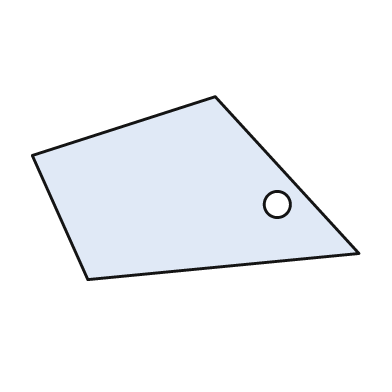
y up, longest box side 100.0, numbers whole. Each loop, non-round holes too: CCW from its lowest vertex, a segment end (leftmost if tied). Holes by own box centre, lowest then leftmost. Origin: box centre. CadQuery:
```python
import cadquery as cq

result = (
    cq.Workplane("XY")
    .moveTo(-33.0, -28.0)
    .lineTo(50.0, -20.0)
    .lineTo(6.0, 28.0)
    .lineTo(-50.0, 10.0)
    .close()
    .moveTo(25.0, -5.0)
    .circle(4.0)
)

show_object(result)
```